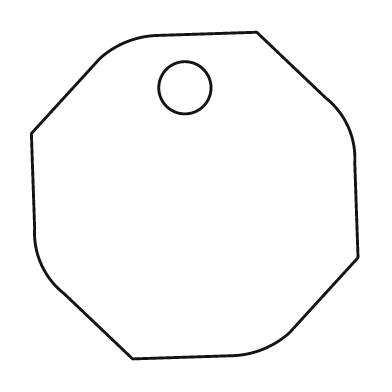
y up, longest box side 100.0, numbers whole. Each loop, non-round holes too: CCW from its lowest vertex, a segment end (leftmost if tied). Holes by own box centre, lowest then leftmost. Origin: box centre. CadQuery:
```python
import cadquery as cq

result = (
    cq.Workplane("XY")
    .moveTo(-19.0, -50.0)
    .lineTo(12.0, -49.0)
    .threePointArc((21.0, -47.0), (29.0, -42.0))
    .lineTo(50.0, -19.0)
    .lineTo(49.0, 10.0)
    .threePointArc((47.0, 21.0), (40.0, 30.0))
    .lineTo(19.0, 50.0)
    .lineTo(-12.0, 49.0)
    .threePointArc((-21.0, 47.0), (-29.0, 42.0))
    .lineTo(-50.0, 19.0)
    .lineTo(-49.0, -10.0)
    .threePointArc((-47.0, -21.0), (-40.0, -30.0))
    .close()
    .moveTo(-3.0, 33.0)
    .circle(8.0)
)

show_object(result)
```